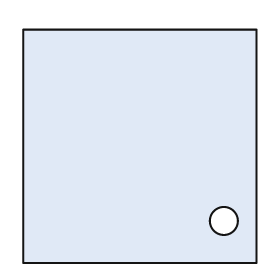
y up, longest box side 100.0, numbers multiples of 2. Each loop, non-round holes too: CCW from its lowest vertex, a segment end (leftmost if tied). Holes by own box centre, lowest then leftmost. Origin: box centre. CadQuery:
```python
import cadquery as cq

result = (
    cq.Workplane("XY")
    .moveTo(-50.0, -50.0)
    .lineTo(50.0, -50.0)
    .lineTo(50.0, 50.0)
    .lineTo(-50.0, 50.0)
    .close()
    .moveTo(36.0, -32.0)
    .circle(6.0)
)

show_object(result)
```